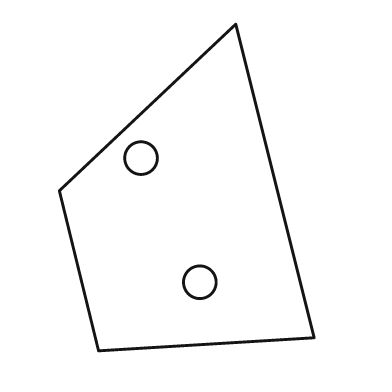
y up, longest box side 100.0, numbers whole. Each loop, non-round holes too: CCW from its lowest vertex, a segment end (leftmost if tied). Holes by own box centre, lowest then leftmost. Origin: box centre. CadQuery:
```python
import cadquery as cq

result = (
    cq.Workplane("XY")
    .moveTo(-27.0, -50.0)
    .lineTo(39.0, -46.0)
    .lineTo(15.0, 50.0)
    .lineTo(-39.0, -1.0)
    .close()
    .moveTo(4.0, -29.0)
    .circle(5.0)
    .moveTo(-14.0, 9.0)
    .circle(5.0)
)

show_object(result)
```